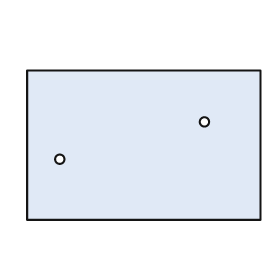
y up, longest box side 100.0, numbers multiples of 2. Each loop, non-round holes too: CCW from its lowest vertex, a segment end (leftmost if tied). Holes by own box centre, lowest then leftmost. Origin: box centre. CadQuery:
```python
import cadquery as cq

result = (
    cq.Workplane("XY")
    .moveTo(-50.0, -32.0)
    .lineTo(50.0, -32.0)
    .lineTo(50.0, 32.0)
    .lineTo(-50.0, 32.0)
    .close()
    .moveTo(-36.0, -6.0)
    .circle(2.0)
    .moveTo(26.0, 10.0)
    .circle(2.0)
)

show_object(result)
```